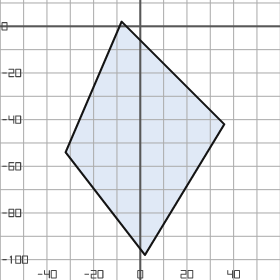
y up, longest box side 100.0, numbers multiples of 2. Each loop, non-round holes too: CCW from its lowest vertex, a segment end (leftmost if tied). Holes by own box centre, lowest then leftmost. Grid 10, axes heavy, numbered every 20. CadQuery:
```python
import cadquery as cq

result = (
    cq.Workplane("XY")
    .moveTo(2.0, -98.0)
    .lineTo(36.0, -42.0)
    .lineTo(-8.0, 2.0)
    .lineTo(-32.0, -54.0)
    .close()
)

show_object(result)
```